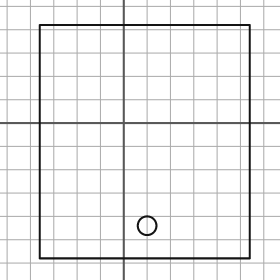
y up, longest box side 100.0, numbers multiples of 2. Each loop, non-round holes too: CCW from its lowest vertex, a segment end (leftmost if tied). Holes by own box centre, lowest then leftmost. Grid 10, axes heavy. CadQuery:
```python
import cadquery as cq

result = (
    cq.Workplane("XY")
    .moveTo(-36.0, -58.0)
    .lineTo(54.0, -58.0)
    .lineTo(54.0, 42.0)
    .lineTo(-36.0, 42.0)
    .close()
    .moveTo(10.0, -44.0)
    .circle(4.0)
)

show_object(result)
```